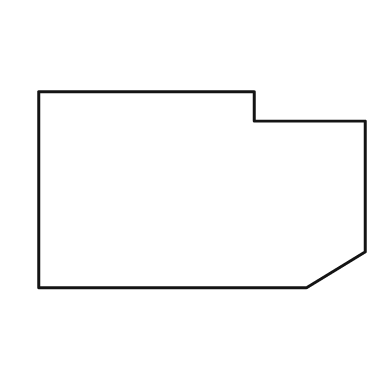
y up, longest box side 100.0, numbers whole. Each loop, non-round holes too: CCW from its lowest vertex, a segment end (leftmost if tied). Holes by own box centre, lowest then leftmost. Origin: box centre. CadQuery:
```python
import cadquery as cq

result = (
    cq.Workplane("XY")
    .moveTo(-50.0, -30.0)
    .lineTo(32.0, -30.0)
    .lineTo(50.0, -19.0)
    .lineTo(50.0, 21.0)
    .lineTo(16.0, 21.0)
    .lineTo(16.0, 30.0)
    .lineTo(-50.0, 30.0)
    .close()
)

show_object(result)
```